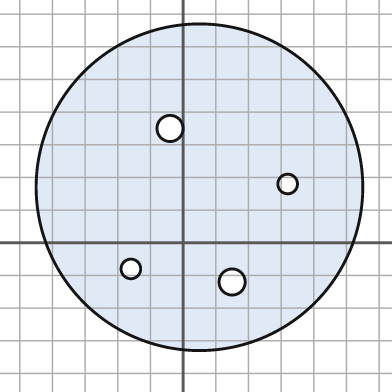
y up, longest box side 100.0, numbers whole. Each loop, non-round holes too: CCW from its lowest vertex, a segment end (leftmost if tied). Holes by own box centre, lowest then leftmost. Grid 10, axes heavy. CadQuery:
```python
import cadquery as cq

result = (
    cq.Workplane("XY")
    .moveTo(5.0, 17.0)
    .circle(50.0)
    .moveTo(15.0, -12.0)
    .circle(4.0)
    .moveTo(-16.0, -8.0)
    .circle(3.0)
    .moveTo(32.0, 18.0)
    .circle(3.0)
    .moveTo(-4.0, 35.0)
    .circle(4.0)
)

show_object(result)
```